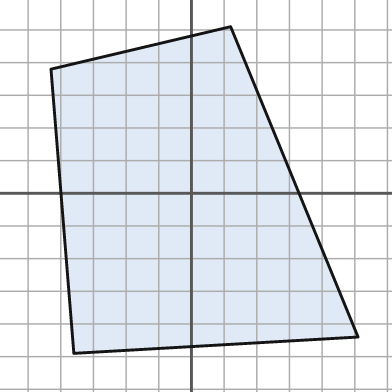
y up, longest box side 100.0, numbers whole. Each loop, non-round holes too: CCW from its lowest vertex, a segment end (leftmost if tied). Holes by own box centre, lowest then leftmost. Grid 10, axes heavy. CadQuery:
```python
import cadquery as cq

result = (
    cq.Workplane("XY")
    .moveTo(-36.0, -49.0)
    .lineTo(51.0, -44.0)
    .lineTo(12.0, 51.0)
    .lineTo(-43.0, 38.0)
    .close()
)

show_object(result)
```